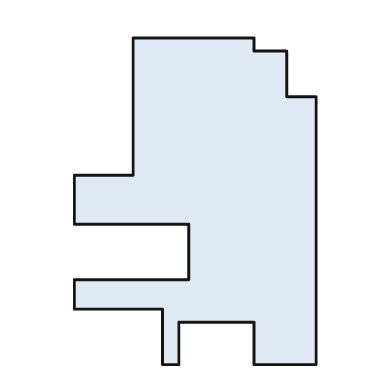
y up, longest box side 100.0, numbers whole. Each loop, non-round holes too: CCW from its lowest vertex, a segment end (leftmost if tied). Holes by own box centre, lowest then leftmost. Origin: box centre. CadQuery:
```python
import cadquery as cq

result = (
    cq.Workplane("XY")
    .moveTo(-10.0, -50.0)
    .lineTo(-5.0, -50.0)
    .lineTo(-5.0, -37.0)
    .lineTo(18.0, -37.0)
    .lineTo(18.0, -50.0)
    .lineTo(37.0, -50.0)
    .lineTo(37.0, 32.0)
    .lineTo(28.0, 32.0)
    .lineTo(28.0, 46.0)
    .lineTo(18.0, 46.0)
    .lineTo(18.0, 50.0)
    .lineTo(-19.0, 50.0)
    .lineTo(-19.0, 8.0)
    .lineTo(-37.0, 8.0)
    .lineTo(-37.0, -7.0)
    .lineTo(-2.0, -7.0)
    .lineTo(-2.0, -24.0)
    .lineTo(-37.0, -24.0)
    .lineTo(-37.0, -33.0)
    .lineTo(-10.0, -33.0)
    .close()
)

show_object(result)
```